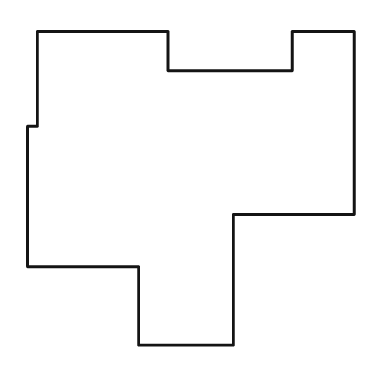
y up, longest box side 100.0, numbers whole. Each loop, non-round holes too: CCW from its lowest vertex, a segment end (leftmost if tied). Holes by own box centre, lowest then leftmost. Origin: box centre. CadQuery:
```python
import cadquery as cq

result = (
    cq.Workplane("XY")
    .moveTo(-16.0, -48.0)
    .lineTo(13.0, -48.0)
    .lineTo(13.0, -8.0)
    .lineTo(50.0, -8.0)
    .lineTo(50.0, 48.0)
    .lineTo(31.0, 48.0)
    .lineTo(31.0, 36.0)
    .lineTo(-7.0, 36.0)
    .lineTo(-7.0, 48.0)
    .lineTo(-47.0, 48.0)
    .lineTo(-47.0, 19.0)
    .lineTo(-50.0, 19.0)
    .lineTo(-50.0, -24.0)
    .lineTo(-16.0, -24.0)
    .close()
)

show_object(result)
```